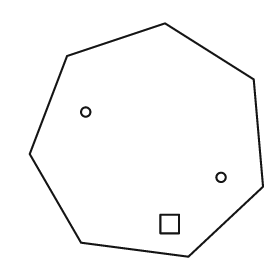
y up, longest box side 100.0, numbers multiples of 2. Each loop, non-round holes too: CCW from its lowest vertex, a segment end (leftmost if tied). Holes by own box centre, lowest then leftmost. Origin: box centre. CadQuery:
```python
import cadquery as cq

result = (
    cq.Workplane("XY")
    .moveTo(18.0, -50.0)
    .lineTo(50.0, -20.0)
    .lineTo(46.0, 26.0)
    .lineTo(8.0, 50.0)
    .lineTo(-34.0, 36.0)
    .lineTo(-50.0, -6.0)
    .lineTo(-28.0, -44.0)
    .close()
    .moveTo(6.0, -40.0)
    .lineTo(14.0, -40.0)
    .lineTo(14.0, -32.0)
    .lineTo(6.0, -32.0)
    .close()
    .moveTo(32.0, -16.0)
    .circle(2.0)
    .moveTo(-26.0, 12.0)
    .circle(2.0)
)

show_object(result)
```